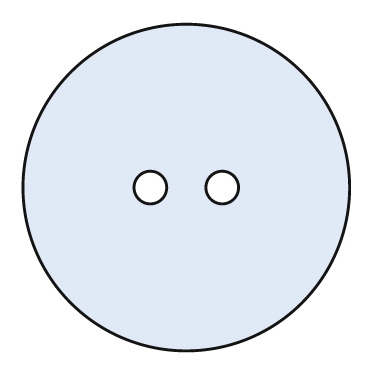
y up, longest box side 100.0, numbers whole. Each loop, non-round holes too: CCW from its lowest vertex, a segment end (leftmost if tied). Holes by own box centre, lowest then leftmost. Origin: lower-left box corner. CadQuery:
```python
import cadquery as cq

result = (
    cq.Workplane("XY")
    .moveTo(50.0, 50.0)
    .circle(50.0)
    .moveTo(39.0, 50.0)
    .circle(5.0)
    .moveTo(61.0, 50.0)
    .circle(5.0)
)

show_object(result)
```